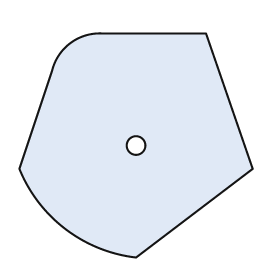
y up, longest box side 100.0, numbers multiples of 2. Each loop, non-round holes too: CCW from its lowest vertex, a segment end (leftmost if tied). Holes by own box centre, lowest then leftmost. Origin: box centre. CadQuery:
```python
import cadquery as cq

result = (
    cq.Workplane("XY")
    .moveTo(0.0, -48.0)
    .lineTo(50.0, -10.0)
    .lineTo(30.0, 48.0)
    .lineTo(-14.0, 48.0)
    .threePointArc((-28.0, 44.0), (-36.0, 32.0))
    .lineTo(-50.0, -10.0)
    .threePointArc((-30.0, -36.0), (0.0, -48.0))
    .close()
    .moveTo(0.0, 0.0)
    .circle(4.0)
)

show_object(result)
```